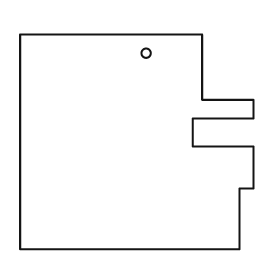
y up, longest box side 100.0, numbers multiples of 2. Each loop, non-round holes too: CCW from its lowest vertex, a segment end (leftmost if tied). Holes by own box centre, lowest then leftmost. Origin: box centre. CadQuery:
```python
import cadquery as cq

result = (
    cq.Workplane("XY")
    .moveTo(-50.0, -46.0)
    .lineTo(44.0, -46.0)
    .lineTo(44.0, -20.0)
    .lineTo(50.0, -20.0)
    .lineTo(50.0, -2.0)
    .lineTo(24.0, -2.0)
    .lineTo(24.0, 10.0)
    .lineTo(50.0, 10.0)
    .lineTo(50.0, 18.0)
    .lineTo(28.0, 18.0)
    .lineTo(28.0, 46.0)
    .lineTo(-50.0, 46.0)
    .close()
    .moveTo(4.0, 38.0)
    .circle(2.0)
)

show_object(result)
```